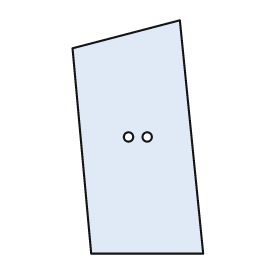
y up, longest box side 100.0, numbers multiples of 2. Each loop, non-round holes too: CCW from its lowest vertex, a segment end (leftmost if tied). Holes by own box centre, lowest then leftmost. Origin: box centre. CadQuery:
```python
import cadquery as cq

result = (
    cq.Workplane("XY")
    .moveTo(-20.0, -50.0)
    .lineTo(28.0, -50.0)
    .lineTo(18.0, 50.0)
    .lineTo(-28.0, 38.0)
    .close()
    .moveTo(-4.0, 0.0)
    .circle(2.0)
    .moveTo(4.0, 0.0)
    .circle(2.0)
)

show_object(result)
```